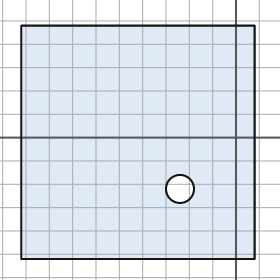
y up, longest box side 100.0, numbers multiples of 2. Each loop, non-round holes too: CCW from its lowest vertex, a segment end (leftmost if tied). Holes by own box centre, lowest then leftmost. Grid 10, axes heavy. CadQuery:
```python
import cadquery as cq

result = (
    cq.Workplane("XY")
    .moveTo(-92.0, -52.0)
    .lineTo(8.0, -52.0)
    .lineTo(8.0, 48.0)
    .lineTo(-92.0, 48.0)
    .close()
    .moveTo(-24.0, -22.0)
    .circle(6.0)
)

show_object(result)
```